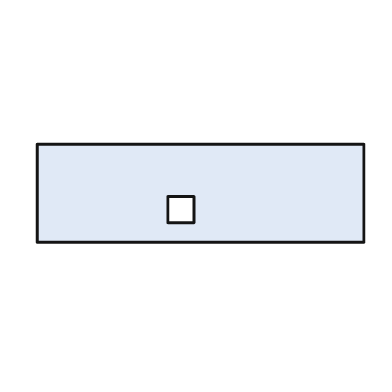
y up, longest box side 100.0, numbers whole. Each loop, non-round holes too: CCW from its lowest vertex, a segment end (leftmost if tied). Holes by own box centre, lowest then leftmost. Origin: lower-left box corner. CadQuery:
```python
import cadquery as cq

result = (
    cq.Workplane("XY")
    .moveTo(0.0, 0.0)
    .lineTo(100.0, 0.0)
    .lineTo(100.0, 30.0)
    .lineTo(0.0, 30.0)
    .close()
    .moveTo(40.0, 6.0)
    .lineTo(48.0, 6.0)
    .lineTo(48.0, 14.0)
    .lineTo(40.0, 14.0)
    .close()
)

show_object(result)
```